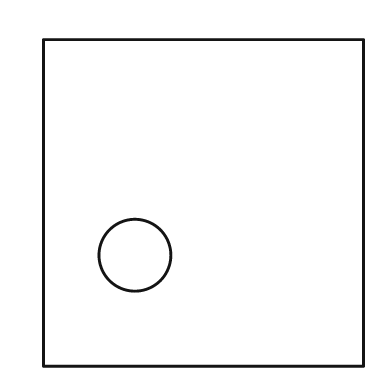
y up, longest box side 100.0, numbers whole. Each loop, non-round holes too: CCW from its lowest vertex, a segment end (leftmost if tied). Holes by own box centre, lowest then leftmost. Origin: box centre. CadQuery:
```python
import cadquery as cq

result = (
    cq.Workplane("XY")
    .moveTo(-49.0, -50.0)
    .lineTo(49.0, -50.0)
    .lineTo(49.0, 50.0)
    .lineTo(-49.0, 50.0)
    .close()
    .moveTo(-21.0, -16.0)
    .circle(11.0)
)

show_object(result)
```